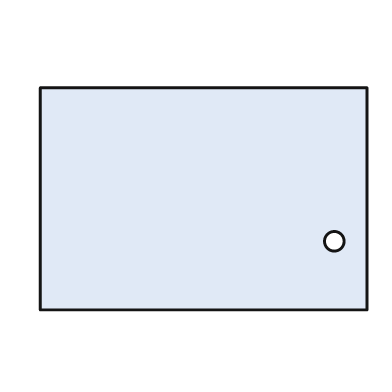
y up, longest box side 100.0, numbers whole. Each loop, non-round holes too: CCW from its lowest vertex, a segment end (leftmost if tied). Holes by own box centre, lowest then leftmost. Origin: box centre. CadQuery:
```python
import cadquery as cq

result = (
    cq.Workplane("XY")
    .moveTo(-50.0, -34.0)
    .lineTo(50.0, -34.0)
    .lineTo(50.0, 34.0)
    .lineTo(-50.0, 34.0)
    .close()
    .moveTo(40.0, -13.0)
    .circle(3.0)
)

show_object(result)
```